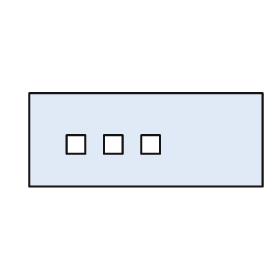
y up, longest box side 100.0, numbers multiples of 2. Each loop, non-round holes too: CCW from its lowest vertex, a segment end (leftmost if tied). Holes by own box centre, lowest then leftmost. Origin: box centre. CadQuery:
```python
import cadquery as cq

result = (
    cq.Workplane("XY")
    .moveTo(-50.0, -20.0)
    .lineTo(50.0, -20.0)
    .lineTo(50.0, 20.0)
    .lineTo(-50.0, 20.0)
    .close()
    .moveTo(-34.0, -6.0)
    .lineTo(-26.0, -6.0)
    .lineTo(-26.0, 2.0)
    .lineTo(-34.0, 2.0)
    .close()
    .moveTo(-18.0, -6.0)
    .lineTo(-10.0, -6.0)
    .lineTo(-10.0, 2.0)
    .lineTo(-18.0, 2.0)
    .close()
    .moveTo(-2.0, -6.0)
    .lineTo(6.0, -6.0)
    .lineTo(6.0, 2.0)
    .lineTo(-2.0, 2.0)
    .close()
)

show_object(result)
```